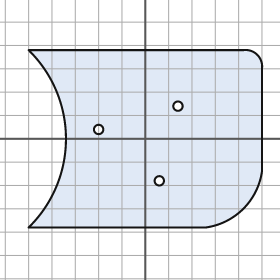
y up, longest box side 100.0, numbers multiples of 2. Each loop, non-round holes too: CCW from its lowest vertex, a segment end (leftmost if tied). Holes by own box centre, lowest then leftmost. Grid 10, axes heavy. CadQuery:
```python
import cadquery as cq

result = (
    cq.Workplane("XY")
    .moveTo(-50.0, -38.0)
    .lineTo(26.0, -38.0)
    .threePointArc((42.0, -30.0), (50.0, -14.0))
    .lineTo(50.0, 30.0)
    .threePointArc((48.0, 36.0), (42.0, 38.0))
    .lineTo(-50.0, 38.0)
    .threePointArc((-34.0, 0.0), (-50.0, -38.0))
    .close()
    .moveTo(6.0, -18.0)
    .circle(2.0)
    .moveTo(-20.0, 4.0)
    .circle(2.0)
    .moveTo(14.0, 14.0)
    .circle(2.0)
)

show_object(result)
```